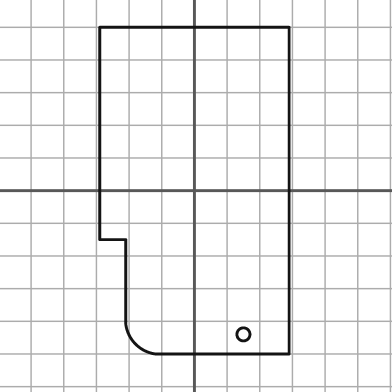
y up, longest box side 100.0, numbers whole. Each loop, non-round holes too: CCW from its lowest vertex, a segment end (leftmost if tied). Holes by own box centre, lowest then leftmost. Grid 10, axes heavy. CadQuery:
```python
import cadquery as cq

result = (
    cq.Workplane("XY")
    .moveTo(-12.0, -50.0)
    .lineTo(29.0, -50.0)
    .lineTo(29.0, 50.0)
    .lineTo(-29.0, 50.0)
    .lineTo(-29.0, -15.0)
    .lineTo(-21.0, -15.0)
    .lineTo(-21.0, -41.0)
    .threePointArc((-18.0, -47.0), (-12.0, -50.0))
    .close()
    .moveTo(15.0, -44.0)
    .circle(2.0)
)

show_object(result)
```